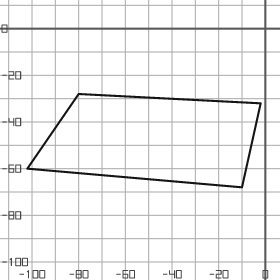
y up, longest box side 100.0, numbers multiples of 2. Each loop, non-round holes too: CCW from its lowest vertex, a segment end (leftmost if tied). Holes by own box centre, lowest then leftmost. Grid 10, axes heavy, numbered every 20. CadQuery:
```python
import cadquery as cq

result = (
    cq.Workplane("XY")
    .moveTo(-10.0, -68.0)
    .lineTo(-2.0, -32.0)
    .lineTo(-80.0, -28.0)
    .lineTo(-102.0, -60.0)
    .close()
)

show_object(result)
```